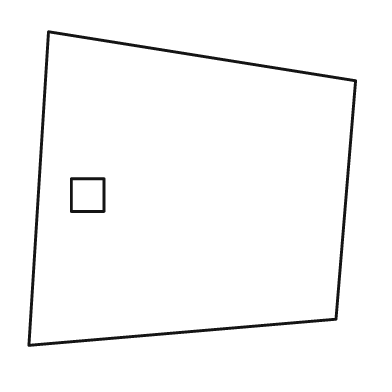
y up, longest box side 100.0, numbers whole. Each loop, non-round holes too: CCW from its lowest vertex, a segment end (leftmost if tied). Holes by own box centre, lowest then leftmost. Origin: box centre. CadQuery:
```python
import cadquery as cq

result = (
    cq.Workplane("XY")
    .moveTo(-50.0, -48.0)
    .lineTo(44.0, -40.0)
    .lineTo(50.0, 33.0)
    .lineTo(-44.0, 48.0)
    .close()
    .moveTo(-37.0, -7.0)
    .lineTo(-27.0, -7.0)
    .lineTo(-27.0, 3.0)
    .lineTo(-37.0, 3.0)
    .close()
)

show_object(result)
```